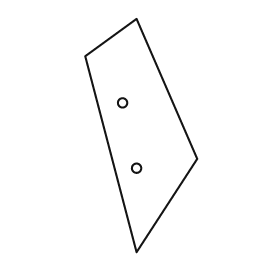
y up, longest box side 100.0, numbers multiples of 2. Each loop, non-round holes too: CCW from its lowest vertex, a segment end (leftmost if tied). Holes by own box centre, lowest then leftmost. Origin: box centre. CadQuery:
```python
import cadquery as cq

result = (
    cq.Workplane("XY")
    .moveTo(-2.0, -50.0)
    .lineTo(24.0, -10.0)
    .lineTo(-2.0, 50.0)
    .lineTo(-24.0, 34.0)
    .close()
    .moveTo(-2.0, -14.0)
    .circle(2.0)
    .moveTo(-8.0, 14.0)
    .circle(2.0)
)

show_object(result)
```